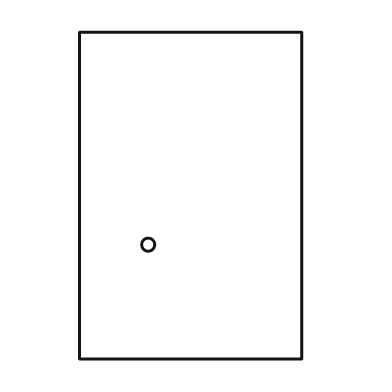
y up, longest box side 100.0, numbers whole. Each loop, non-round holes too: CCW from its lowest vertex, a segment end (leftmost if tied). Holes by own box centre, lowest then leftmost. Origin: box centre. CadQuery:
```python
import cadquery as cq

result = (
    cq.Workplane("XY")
    .moveTo(-34.0, -50.0)
    .lineTo(34.0, -50.0)
    .lineTo(34.0, 50.0)
    .lineTo(-34.0, 50.0)
    .close()
    .moveTo(-13.0, -15.0)
    .circle(2.0)
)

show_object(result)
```